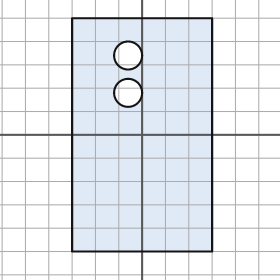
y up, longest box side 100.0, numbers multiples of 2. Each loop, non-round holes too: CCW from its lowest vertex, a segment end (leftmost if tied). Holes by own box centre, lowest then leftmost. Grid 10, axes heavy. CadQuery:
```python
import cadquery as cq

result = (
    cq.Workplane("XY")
    .moveTo(-30.0, -50.0)
    .lineTo(30.0, -50.0)
    .lineTo(30.0, 50.0)
    .lineTo(-30.0, 50.0)
    .close()
    .moveTo(-6.0, 18.0)
    .circle(6.0)
    .moveTo(-6.0, 34.0)
    .circle(6.0)
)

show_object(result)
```